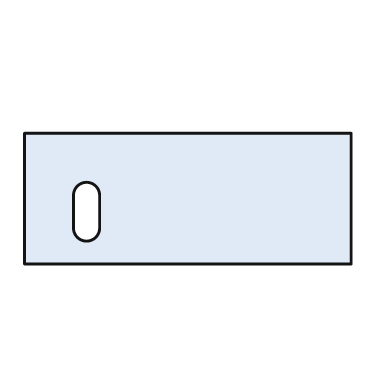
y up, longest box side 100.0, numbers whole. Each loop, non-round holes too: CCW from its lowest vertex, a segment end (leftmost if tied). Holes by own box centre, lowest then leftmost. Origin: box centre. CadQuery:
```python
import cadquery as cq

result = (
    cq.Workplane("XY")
    .moveTo(-50.0, -20.0)
    .lineTo(50.0, -20.0)
    .lineTo(50.0, 20.0)
    .lineTo(-50.0, 20.0)
    .close()
    .moveTo(-35.0, -9.0)
    .threePointArc((-31.0, -13.0), (-27.0, -9.0))
    .lineTo(-27.0, 1.0)
    .threePointArc((-31.0, 5.0), (-35.0, 1.0))
    .close()
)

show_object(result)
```